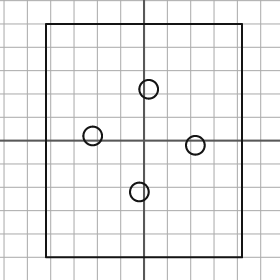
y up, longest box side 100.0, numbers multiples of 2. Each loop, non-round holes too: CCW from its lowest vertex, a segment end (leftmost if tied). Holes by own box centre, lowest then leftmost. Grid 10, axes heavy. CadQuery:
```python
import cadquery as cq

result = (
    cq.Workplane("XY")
    .moveTo(-42.0, -50.0)
    .lineTo(42.0, -50.0)
    .lineTo(42.0, 50.0)
    .lineTo(-42.0, 50.0)
    .close()
    .moveTo(-2.0, -22.0)
    .circle(4.0)
    .moveTo(22.0, -2.0)
    .circle(4.0)
    .moveTo(-22.0, 2.0)
    .circle(4.0)
    .moveTo(2.0, 22.0)
    .circle(4.0)
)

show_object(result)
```